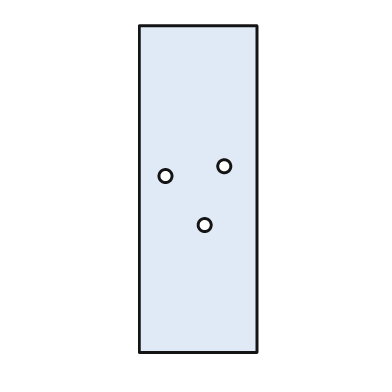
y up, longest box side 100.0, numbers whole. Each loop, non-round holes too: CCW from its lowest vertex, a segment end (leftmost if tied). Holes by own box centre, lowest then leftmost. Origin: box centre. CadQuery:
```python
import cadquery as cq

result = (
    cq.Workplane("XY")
    .moveTo(-18.0, -50.0)
    .lineTo(18.0, -50.0)
    .lineTo(18.0, 50.0)
    .lineTo(-18.0, 50.0)
    .close()
    .moveTo(2.0, -11.0)
    .circle(2.0)
    .moveTo(-10.0, 4.0)
    .circle(2.0)
    .moveTo(8.0, 7.0)
    .circle(2.0)
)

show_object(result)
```